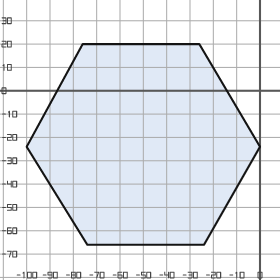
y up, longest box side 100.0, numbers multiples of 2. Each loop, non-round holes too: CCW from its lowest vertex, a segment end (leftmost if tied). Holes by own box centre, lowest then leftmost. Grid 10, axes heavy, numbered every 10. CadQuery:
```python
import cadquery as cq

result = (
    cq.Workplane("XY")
    .moveTo(-74.0, -66.0)
    .lineTo(-24.0, -66.0)
    .lineTo(0.0, -24.0)
    .lineTo(-26.0, 20.0)
    .lineTo(-76.0, 20.0)
    .lineTo(-100.0, -24.0)
    .close()
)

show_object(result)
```